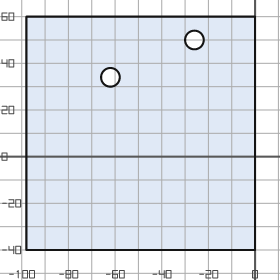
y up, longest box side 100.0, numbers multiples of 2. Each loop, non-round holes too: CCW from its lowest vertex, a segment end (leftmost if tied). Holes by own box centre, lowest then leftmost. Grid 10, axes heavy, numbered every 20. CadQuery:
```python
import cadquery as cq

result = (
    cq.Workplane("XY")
    .moveTo(-98.0, -40.0)
    .lineTo(0.0, -40.0)
    .lineTo(0.0, 60.0)
    .lineTo(-98.0, 60.0)
    .close()
    .moveTo(-62.0, 34.0)
    .circle(4.0)
    .moveTo(-26.0, 50.0)
    .circle(4.0)
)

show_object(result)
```